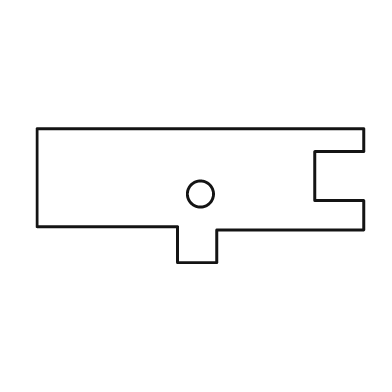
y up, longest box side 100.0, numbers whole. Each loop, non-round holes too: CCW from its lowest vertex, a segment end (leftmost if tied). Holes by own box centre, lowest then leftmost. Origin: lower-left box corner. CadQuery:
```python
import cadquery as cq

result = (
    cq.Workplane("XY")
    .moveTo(43.0, 0.0)
    .lineTo(55.0, 0.0)
    .lineTo(55.0, 10.0)
    .lineTo(100.0, 10.0)
    .lineTo(100.0, 19.0)
    .lineTo(85.0, 19.0)
    .lineTo(85.0, 34.0)
    .lineTo(100.0, 34.0)
    .lineTo(100.0, 41.0)
    .lineTo(0.0, 41.0)
    .lineTo(0.0, 11.0)
    .lineTo(43.0, 11.0)
    .close()
    .moveTo(50.0, 21.0)
    .circle(4.0)
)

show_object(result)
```